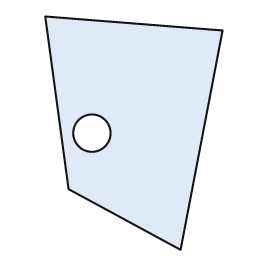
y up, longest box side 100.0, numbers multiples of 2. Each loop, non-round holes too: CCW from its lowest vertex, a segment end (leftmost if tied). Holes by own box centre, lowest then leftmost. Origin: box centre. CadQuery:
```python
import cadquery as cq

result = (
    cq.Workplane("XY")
    .moveTo(20.0, -50.0)
    .lineTo(38.0, 44.0)
    .lineTo(-38.0, 50.0)
    .lineTo(-28.0, -24.0)
    .close()
    .moveTo(-18.0, 0.0)
    .circle(8.0)
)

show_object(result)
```